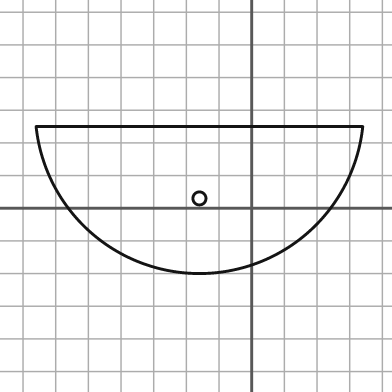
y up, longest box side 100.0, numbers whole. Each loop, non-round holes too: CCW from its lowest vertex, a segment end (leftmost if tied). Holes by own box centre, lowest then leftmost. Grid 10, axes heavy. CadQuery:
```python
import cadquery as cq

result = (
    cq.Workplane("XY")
    .moveTo(-66.0, 25.0)
    .threePointArc((-16.0, -20.0), (34.0, 25.0))
    .close()
    .moveTo(-16.0, 3.0)
    .circle(2.0)
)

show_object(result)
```